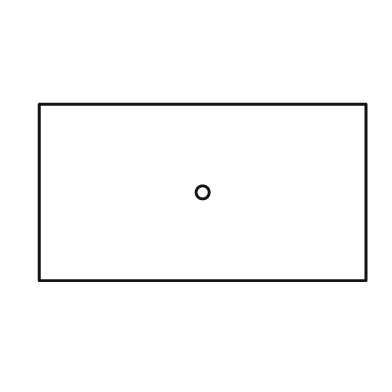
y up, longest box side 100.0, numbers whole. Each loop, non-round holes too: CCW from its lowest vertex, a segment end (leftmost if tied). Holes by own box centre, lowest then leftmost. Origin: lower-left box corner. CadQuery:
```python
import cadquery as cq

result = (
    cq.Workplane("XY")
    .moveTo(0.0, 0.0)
    .lineTo(100.0, 0.0)
    .lineTo(100.0, 54.0)
    .lineTo(0.0, 54.0)
    .close()
    .moveTo(50.0, 27.0)
    .circle(2.0)
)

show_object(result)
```